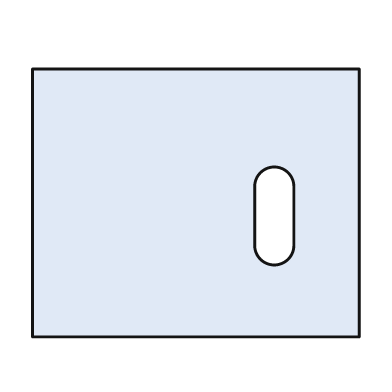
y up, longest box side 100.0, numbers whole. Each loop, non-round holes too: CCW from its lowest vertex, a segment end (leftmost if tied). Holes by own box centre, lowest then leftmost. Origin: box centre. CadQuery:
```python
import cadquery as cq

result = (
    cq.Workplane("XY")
    .moveTo(-50.0, -41.0)
    .lineTo(50.0, -41.0)
    .lineTo(50.0, 41.0)
    .lineTo(-50.0, 41.0)
    .close()
    .moveTo(18.0, -13.0)
    .threePointArc((24.0, -19.0), (30.0, -13.0))
    .lineTo(30.0, 5.0)
    .threePointArc((24.0, 11.0), (18.0, 5.0))
    .close()
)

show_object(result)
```